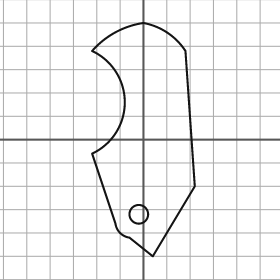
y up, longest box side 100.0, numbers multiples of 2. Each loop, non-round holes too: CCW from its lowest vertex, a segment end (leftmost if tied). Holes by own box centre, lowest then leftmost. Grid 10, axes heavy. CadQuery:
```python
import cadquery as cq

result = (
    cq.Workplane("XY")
    .moveTo(4.0, -50.0)
    .lineTo(22.0, -20.0)
    .lineTo(18.0, 38.0)
    .threePointArc((10.0, 46.0), (0.0, 50.0))
    .threePointArc((-12.0, 46.0), (-22.0, 38.0))
    .threePointArc((-8.0, 16.0), (-22.0, -6.0))
    .lineTo(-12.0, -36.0)
    .threePointArc((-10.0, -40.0), (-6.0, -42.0))
    .close()
    .moveTo(-2.0, -32.0)
    .circle(4.0)
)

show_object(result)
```